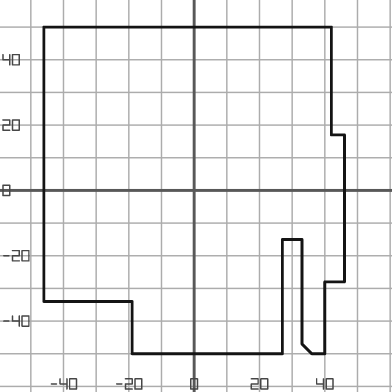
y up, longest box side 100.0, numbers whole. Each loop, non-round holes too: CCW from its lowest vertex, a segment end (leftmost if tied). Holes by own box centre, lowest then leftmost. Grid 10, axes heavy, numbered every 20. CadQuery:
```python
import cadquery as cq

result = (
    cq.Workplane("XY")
    .moveTo(-19.0, -50.0)
    .lineTo(27.0, -50.0)
    .lineTo(27.0, -15.0)
    .lineTo(33.0, -15.0)
    .lineTo(33.0, -47.0)
    .lineTo(36.0, -50.0)
    .lineTo(40.0, -50.0)
    .lineTo(40.0, -28.0)
    .lineTo(46.0, -28.0)
    .lineTo(46.0, 17.0)
    .lineTo(42.0, 17.0)
    .lineTo(42.0, 50.0)
    .lineTo(-46.0, 50.0)
    .lineTo(-46.0, -34.0)
    .lineTo(-19.0, -34.0)
    .close()
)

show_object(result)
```